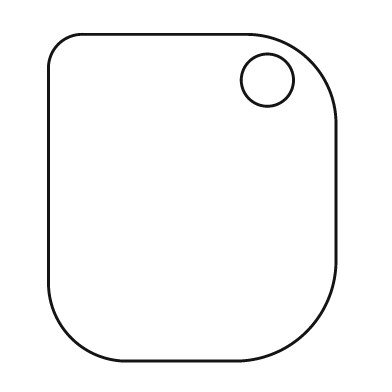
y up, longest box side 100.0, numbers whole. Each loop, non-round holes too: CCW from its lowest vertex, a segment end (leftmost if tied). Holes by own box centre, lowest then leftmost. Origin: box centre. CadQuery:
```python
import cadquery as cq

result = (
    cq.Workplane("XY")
    .moveTo(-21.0, -50.0)
    .lineTo(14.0, -50.0)
    .threePointArc((35.0, -41.0), (44.0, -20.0))
    .lineTo(44.0, 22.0)
    .threePointArc((36.0, 42.0), (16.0, 50.0))
    .lineTo(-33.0, 50.0)
    .threePointArc((-41.0, 47.0), (-44.0, 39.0))
    .lineTo(-44.0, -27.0)
    .threePointArc((-37.0, -43.0), (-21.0, -50.0))
    .close()
    .moveTo(23.0, 36.0)
    .circle(8.0)
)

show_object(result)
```